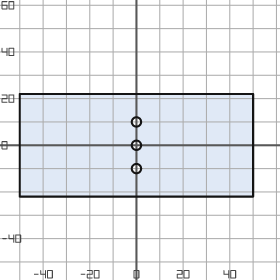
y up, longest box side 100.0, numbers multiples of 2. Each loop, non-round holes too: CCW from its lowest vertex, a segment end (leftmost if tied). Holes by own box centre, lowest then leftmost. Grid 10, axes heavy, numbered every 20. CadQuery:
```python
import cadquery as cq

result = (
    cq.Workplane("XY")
    .moveTo(-50.0, -22.0)
    .lineTo(50.0, -22.0)
    .lineTo(50.0, 22.0)
    .lineTo(-50.0, 22.0)
    .close()
    .moveTo(0.0, -10.0)
    .circle(2.0)
    .moveTo(0.0, 0.0)
    .circle(2.0)
    .moveTo(0.0, 10.0)
    .circle(2.0)
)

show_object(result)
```